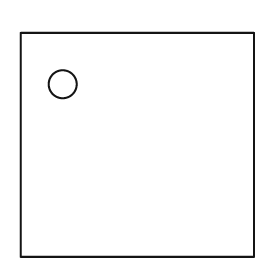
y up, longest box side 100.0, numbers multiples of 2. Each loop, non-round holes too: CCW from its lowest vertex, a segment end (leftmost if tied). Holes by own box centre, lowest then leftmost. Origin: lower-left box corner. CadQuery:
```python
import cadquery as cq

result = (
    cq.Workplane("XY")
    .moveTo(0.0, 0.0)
    .lineTo(100.0, 0.0)
    .lineTo(100.0, 96.0)
    .lineTo(0.0, 96.0)
    .close()
    .moveTo(18.0, 74.0)
    .circle(6.0)
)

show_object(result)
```